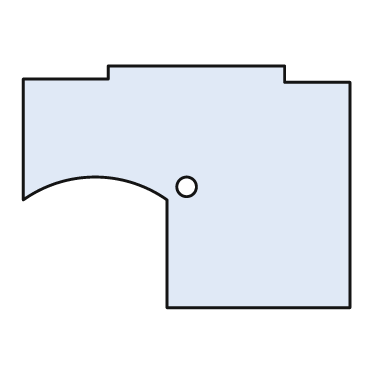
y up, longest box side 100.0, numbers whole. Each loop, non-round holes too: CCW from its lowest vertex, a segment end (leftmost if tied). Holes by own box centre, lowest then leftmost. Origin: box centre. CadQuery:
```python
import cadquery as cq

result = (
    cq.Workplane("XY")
    .moveTo(-6.0, -37.0)
    .lineTo(50.0, -37.0)
    .lineTo(50.0, 32.0)
    .lineTo(30.0, 32.0)
    .lineTo(30.0, 37.0)
    .lineTo(-24.0, 37.0)
    .lineTo(-24.0, 33.0)
    .lineTo(-50.0, 33.0)
    .lineTo(-50.0, -4.0)
    .threePointArc((-28.0, 3.0), (-6.0, -4.0))
    .close()
    .moveTo(0.0, 0.0)
    .circle(3.0)
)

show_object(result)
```